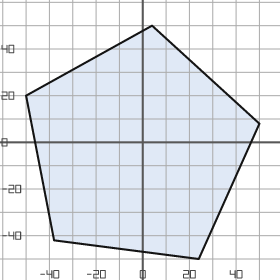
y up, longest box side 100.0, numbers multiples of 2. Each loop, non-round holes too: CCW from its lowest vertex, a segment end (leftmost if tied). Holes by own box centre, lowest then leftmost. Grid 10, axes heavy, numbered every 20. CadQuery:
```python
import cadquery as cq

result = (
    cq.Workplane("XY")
    .moveTo(24.0, -50.0)
    .lineTo(50.0, 8.0)
    .lineTo(4.0, 50.0)
    .lineTo(-50.0, 20.0)
    .lineTo(-38.0, -42.0)
    .close()
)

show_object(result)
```